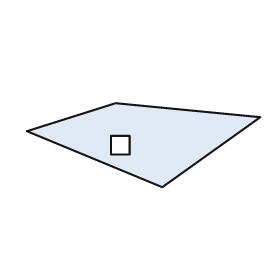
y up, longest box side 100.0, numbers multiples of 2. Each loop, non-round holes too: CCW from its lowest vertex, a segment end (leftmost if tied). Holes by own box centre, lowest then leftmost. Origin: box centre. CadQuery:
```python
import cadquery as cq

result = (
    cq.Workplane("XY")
    .moveTo(8.0, -18.0)
    .lineTo(50.0, 12.0)
    .lineTo(-12.0, 18.0)
    .lineTo(-50.0, 6.0)
    .close()
    .moveTo(-14.0, -4.0)
    .lineTo(-6.0, -4.0)
    .lineTo(-6.0, 4.0)
    .lineTo(-14.0, 4.0)
    .close()
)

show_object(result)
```